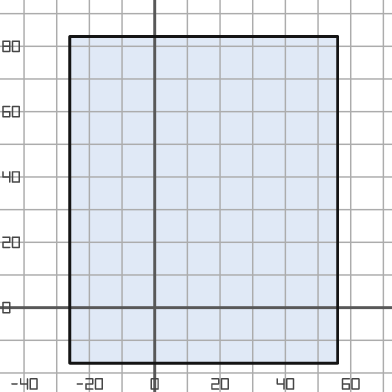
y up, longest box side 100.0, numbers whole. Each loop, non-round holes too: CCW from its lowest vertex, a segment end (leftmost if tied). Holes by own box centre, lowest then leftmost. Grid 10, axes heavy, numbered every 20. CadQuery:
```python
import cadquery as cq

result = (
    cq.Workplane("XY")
    .moveTo(-26.0, -17.0)
    .lineTo(56.0, -17.0)
    .lineTo(56.0, 83.0)
    .lineTo(-26.0, 83.0)
    .close()
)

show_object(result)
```